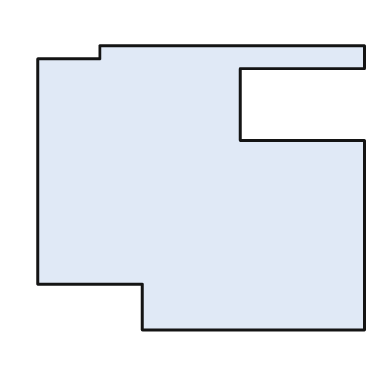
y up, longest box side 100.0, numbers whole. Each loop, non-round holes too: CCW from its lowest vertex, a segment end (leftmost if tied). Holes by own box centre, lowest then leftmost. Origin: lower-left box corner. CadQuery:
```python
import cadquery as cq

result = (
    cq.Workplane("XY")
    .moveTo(32.0, 0.0)
    .lineTo(100.0, 0.0)
    .lineTo(100.0, 58.0)
    .lineTo(62.0, 58.0)
    .lineTo(62.0, 80.0)
    .lineTo(100.0, 80.0)
    .lineTo(100.0, 87.0)
    .lineTo(19.0, 87.0)
    .lineTo(19.0, 83.0)
    .lineTo(0.0, 83.0)
    .lineTo(0.0, 14.0)
    .lineTo(32.0, 14.0)
    .close()
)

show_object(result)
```